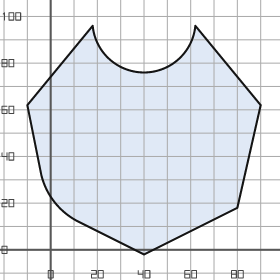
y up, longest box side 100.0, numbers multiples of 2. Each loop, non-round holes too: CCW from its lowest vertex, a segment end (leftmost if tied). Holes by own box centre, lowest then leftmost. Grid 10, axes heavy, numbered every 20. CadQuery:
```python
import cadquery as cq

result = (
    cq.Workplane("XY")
    .moveTo(40.0, -2.0)
    .lineTo(80.0, 18.0)
    .lineTo(90.0, 62.0)
    .lineTo(62.0, 96.0)
    .threePointArc((40.0, 76.0), (18.0, 96.0))
    .lineTo(-10.0, 62.0)
    .lineTo(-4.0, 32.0)
    .threePointArc((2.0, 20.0), (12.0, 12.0))
    .close()
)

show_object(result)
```